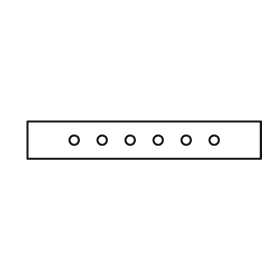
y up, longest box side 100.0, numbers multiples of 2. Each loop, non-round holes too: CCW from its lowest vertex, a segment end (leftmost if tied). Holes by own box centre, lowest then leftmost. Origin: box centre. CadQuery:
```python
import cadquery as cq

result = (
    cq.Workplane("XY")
    .moveTo(-50.0, -8.0)
    .lineTo(50.0, -8.0)
    .lineTo(50.0, 8.0)
    .lineTo(-50.0, 8.0)
    .close()
    .moveTo(-30.0, 0.0)
    .circle(2.0)
    .moveTo(-18.0, 0.0)
    .circle(2.0)
    .moveTo(-6.0, 0.0)
    .circle(2.0)
    .moveTo(6.0, 0.0)
    .circle(2.0)
    .moveTo(18.0, 0.0)
    .circle(2.0)
    .moveTo(30.0, 0.0)
    .circle(2.0)
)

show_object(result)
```